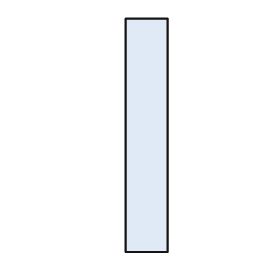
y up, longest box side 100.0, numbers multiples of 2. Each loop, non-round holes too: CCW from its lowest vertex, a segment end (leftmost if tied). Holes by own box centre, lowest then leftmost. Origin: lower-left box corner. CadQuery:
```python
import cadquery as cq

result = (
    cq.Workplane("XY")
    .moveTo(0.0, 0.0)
    .lineTo(18.0, 0.0)
    .lineTo(18.0, 100.0)
    .lineTo(0.0, 100.0)
    .close()
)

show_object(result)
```